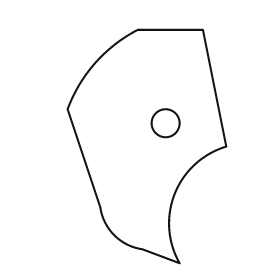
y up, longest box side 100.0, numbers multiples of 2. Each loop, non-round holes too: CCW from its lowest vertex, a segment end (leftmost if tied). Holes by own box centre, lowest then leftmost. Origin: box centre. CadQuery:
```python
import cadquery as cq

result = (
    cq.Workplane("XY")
    .moveTo(14.0, -50.0)
    .threePointArc((12.0, -20.0), (34.0, 0.0))
    .lineTo(24.0, 50.0)
    .lineTo(-4.0, 50.0)
    .threePointArc((-22.0, 36.0), (-34.0, 16.0))
    .lineTo(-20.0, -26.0)
    .threePointArc((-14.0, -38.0), (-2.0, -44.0))
    .close()
    .moveTo(8.0, 10.0)
    .circle(6.0)
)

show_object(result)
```